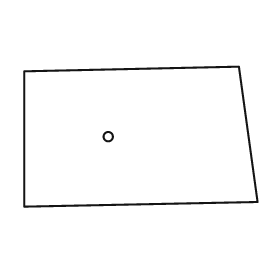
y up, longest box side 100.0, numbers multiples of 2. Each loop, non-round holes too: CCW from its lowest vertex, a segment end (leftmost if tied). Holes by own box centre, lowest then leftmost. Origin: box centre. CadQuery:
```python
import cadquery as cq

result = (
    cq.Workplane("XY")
    .moveTo(-50.0, -30.0)
    .lineTo(50.0, -28.0)
    .lineTo(42.0, 30.0)
    .lineTo(-50.0, 28.0)
    .close()
    .moveTo(-14.0, 0.0)
    .circle(2.0)
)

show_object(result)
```